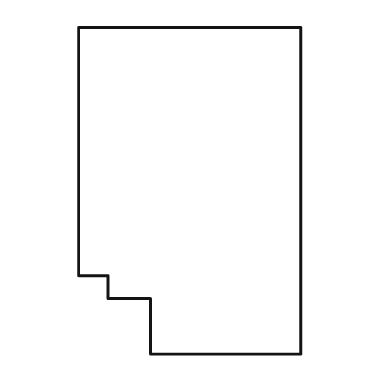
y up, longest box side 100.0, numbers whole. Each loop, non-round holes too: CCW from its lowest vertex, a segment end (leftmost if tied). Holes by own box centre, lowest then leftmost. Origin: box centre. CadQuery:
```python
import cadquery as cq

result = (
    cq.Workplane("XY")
    .moveTo(-12.0, -50.0)
    .lineTo(34.0, -50.0)
    .lineTo(34.0, 50.0)
    .lineTo(-34.0, 50.0)
    .lineTo(-34.0, -26.0)
    .lineTo(-25.0, -26.0)
    .lineTo(-25.0, -33.0)
    .lineTo(-12.0, -33.0)
    .close()
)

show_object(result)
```